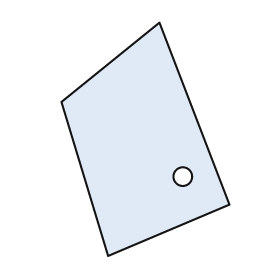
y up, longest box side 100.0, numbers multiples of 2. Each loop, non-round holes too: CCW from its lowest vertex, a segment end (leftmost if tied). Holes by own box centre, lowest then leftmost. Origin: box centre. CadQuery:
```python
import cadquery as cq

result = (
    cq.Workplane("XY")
    .moveTo(-16.0, -50.0)
    .lineTo(36.0, -28.0)
    .lineTo(6.0, 50.0)
    .lineTo(-36.0, 16.0)
    .close()
    .moveTo(16.0, -16.0)
    .circle(4.0)
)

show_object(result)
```